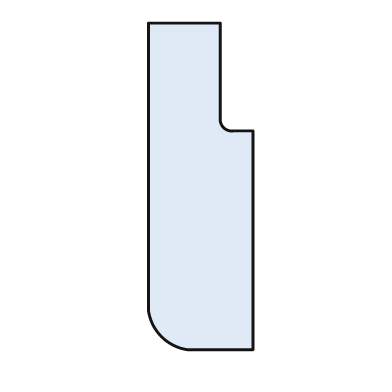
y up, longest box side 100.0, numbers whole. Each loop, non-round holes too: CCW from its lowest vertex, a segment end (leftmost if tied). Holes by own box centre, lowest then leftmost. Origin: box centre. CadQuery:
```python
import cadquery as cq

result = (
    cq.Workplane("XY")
    .moveTo(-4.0, -50.0)
    .lineTo(16.0, -50.0)
    .lineTo(16.0, 17.0)
    .lineTo(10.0, 17.0)
    .threePointArc((7.0, 18.0), (6.0, 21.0))
    .lineTo(6.0, 50.0)
    .lineTo(-16.0, 50.0)
    .lineTo(-16.0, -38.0)
    .threePointArc((-12.0, -46.0), (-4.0, -50.0))
    .close()
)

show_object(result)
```